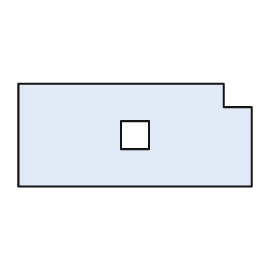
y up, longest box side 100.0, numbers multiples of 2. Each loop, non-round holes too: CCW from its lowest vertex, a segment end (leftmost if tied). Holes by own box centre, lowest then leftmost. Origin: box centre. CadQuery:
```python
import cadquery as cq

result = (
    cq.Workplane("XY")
    .moveTo(-50.0, -22.0)
    .lineTo(50.0, -22.0)
    .lineTo(50.0, 12.0)
    .lineTo(38.0, 12.0)
    .lineTo(38.0, 22.0)
    .lineTo(-50.0, 22.0)
    .close()
    .moveTo(-6.0, -6.0)
    .lineTo(6.0, -6.0)
    .lineTo(6.0, 6.0)
    .lineTo(-6.0, 6.0)
    .close()
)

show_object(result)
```